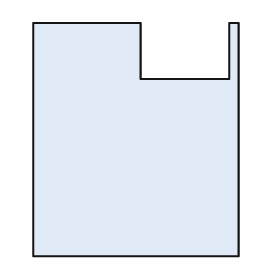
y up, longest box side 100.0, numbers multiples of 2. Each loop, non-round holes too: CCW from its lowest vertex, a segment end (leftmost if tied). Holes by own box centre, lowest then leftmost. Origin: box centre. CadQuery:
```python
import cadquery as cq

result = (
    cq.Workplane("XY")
    .moveTo(-44.0, -50.0)
    .lineTo(44.0, -50.0)
    .lineTo(44.0, 50.0)
    .lineTo(40.0, 50.0)
    .lineTo(40.0, 26.0)
    .lineTo(2.0, 26.0)
    .lineTo(2.0, 50.0)
    .lineTo(-44.0, 50.0)
    .close()
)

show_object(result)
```